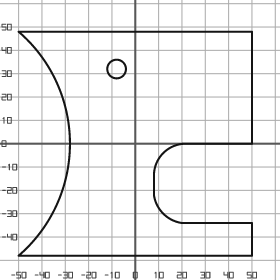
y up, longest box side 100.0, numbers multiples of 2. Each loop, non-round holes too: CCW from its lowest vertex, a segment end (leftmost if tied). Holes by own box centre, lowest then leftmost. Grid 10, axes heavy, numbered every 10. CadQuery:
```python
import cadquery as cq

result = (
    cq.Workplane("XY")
    .moveTo(-50.0, -48.0)
    .lineTo(50.0, -48.0)
    .lineTo(50.0, -34.0)
    .lineTo(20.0, -34.0)
    .threePointArc((12.0, -30.0), (8.0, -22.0))
    .lineTo(8.0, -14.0)
    .threePointArc((12.0, -4.0), (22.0, 0.0))
    .lineTo(50.0, 0.0)
    .lineTo(50.0, 48.0)
    .lineTo(-50.0, 48.0)
    .threePointArc((-28.0, 0.0), (-50.0, -48.0))
    .close()
    .moveTo(-8.0, 32.0)
    .circle(4.0)
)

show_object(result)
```